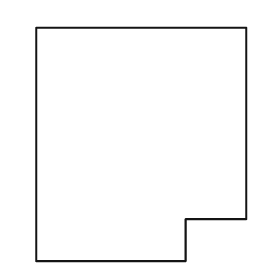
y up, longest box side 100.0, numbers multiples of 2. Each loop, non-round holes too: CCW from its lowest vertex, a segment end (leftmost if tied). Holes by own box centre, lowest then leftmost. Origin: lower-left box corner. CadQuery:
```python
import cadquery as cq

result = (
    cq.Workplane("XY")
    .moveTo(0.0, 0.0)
    .lineTo(64.0, 0.0)
    .lineTo(64.0, 18.0)
    .lineTo(90.0, 18.0)
    .lineTo(90.0, 100.0)
    .lineTo(0.0, 100.0)
    .close()
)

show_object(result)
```